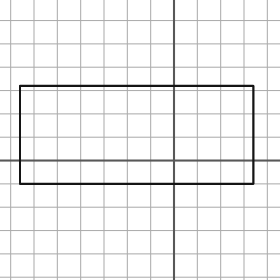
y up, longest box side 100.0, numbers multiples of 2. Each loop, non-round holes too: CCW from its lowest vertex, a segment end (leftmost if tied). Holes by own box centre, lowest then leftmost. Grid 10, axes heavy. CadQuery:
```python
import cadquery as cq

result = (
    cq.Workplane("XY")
    .moveTo(-66.0, -10.0)
    .lineTo(34.0, -10.0)
    .lineTo(34.0, 32.0)
    .lineTo(-66.0, 32.0)
    .close()
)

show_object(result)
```